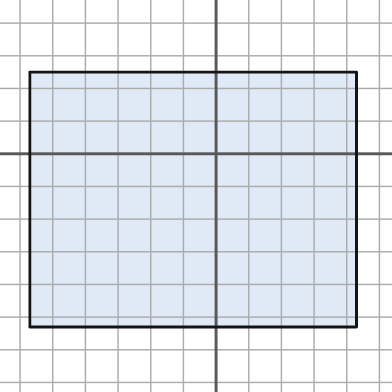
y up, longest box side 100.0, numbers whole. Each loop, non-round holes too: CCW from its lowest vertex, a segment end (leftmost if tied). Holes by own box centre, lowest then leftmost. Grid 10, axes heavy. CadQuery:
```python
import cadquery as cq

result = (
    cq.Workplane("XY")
    .moveTo(-57.0, -53.0)
    .lineTo(43.0, -53.0)
    .lineTo(43.0, 25.0)
    .lineTo(-57.0, 25.0)
    .close()
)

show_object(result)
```